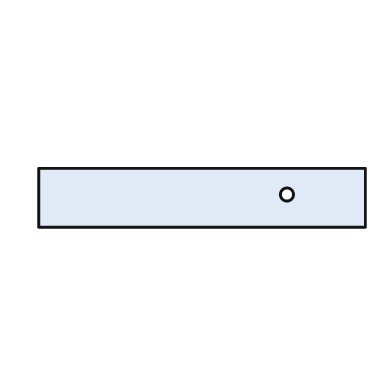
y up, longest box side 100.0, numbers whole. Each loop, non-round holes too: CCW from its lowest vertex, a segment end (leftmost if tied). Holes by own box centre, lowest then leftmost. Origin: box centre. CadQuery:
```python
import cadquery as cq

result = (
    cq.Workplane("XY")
    .moveTo(-50.0, -9.0)
    .lineTo(50.0, -9.0)
    .lineTo(50.0, 9.0)
    .lineTo(-50.0, 9.0)
    .close()
    .moveTo(26.0, 1.0)
    .circle(2.0)
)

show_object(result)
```